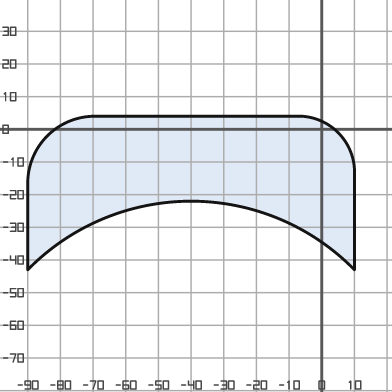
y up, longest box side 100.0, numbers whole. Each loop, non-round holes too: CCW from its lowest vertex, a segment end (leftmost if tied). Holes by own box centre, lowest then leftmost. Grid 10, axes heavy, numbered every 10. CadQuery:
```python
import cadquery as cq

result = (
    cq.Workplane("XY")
    .moveTo(-90.0, -43.0)
    .threePointArc((-40.0, -22.0), (10.0, -43.0))
    .lineTo(10.0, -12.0)
    .threePointArc((5.0, -1.0), (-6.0, 4.0))
    .lineTo(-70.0, 4.0)
    .threePointArc((-84.0, -2.0), (-90.0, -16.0))
    .close()
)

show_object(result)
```